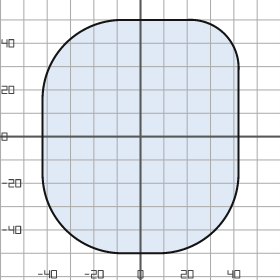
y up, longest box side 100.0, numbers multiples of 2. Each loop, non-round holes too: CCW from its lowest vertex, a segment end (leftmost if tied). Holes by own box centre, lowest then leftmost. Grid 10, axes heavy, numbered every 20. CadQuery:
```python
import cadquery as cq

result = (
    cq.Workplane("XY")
    .moveTo(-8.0, -50.0)
    .lineTo(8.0, -50.0)
    .threePointArc((32.0, -40.0), (42.0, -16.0))
    .lineTo(42.0, 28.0)
    .threePointArc((36.0, 44.0), (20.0, 50.0))
    .lineTo(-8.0, 50.0)
    .threePointArc((-32.0, 40.0), (-42.0, 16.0))
    .lineTo(-42.0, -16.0)
    .threePointArc((-32.0, -40.0), (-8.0, -50.0))
    .close()
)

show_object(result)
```